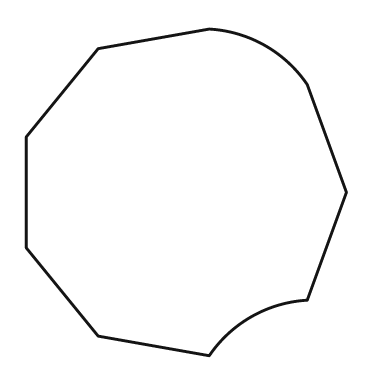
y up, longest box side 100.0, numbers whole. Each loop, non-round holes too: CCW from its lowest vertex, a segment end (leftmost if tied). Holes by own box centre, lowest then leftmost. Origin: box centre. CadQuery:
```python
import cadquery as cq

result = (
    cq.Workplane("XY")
    .moveTo(7.0, -50.0)
    .threePointArc((20.0, -38.0), (37.0, -33.0))
    .lineTo(49.0, 0.0)
    .lineTo(37.0, 33.0)
    .threePointArc((24.0, 45.0), (7.0, 50.0))
    .lineTo(-27.0, 44.0)
    .lineTo(-49.0, 17.0)
    .lineTo(-49.0, -17.0)
    .lineTo(-27.0, -44.0)
    .close()
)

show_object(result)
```